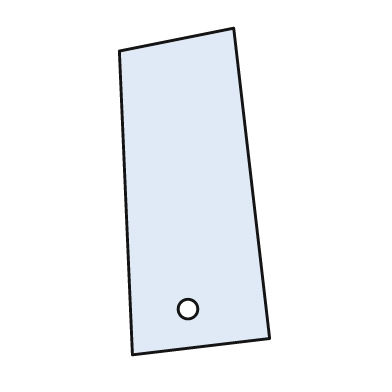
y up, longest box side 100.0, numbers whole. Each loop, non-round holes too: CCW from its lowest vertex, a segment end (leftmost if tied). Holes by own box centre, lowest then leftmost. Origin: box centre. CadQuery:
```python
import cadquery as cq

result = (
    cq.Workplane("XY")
    .moveTo(-19.0, -50.0)
    .lineTo(23.0, -45.0)
    .lineTo(12.0, 50.0)
    .lineTo(-23.0, 43.0)
    .close()
    .moveTo(-2.0, -36.0)
    .circle(3.0)
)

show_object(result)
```